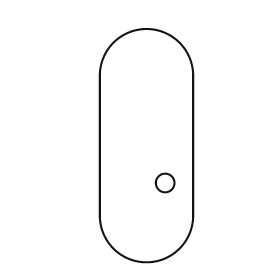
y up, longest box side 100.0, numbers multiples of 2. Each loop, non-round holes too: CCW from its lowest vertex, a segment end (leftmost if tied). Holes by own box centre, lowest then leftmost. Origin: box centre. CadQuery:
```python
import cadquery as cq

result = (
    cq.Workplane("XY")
    .moveTo(-20.0, -30.0)
    .threePointArc((0.0, -50.0), (20.0, -30.0))
    .lineTo(20.0, 30.0)
    .threePointArc((0.0, 50.0), (-20.0, 30.0))
    .close()
    .moveTo(8.0, -16.0)
    .circle(4.0)
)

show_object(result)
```